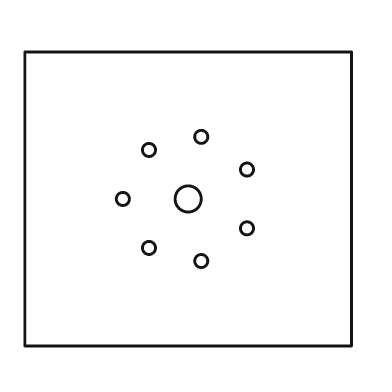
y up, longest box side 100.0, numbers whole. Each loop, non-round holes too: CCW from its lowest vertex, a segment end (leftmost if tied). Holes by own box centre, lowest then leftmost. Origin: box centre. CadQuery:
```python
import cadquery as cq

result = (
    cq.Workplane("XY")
    .moveTo(-50.0, -45.0)
    .lineTo(50.0, -45.0)
    .lineTo(50.0, 45.0)
    .lineTo(-50.0, 45.0)
    .close()
    .moveTo(4.0, -19.0)
    .circle(2.0)
    .moveTo(-12.0, -15.0)
    .circle(2.0)
    .moveTo(18.0, -9.0)
    .circle(2.0)
    .moveTo(-20.0, 0.0)
    .circle(2.0)
    .moveTo(0.0, 0.0)
    .circle(4.0)
    .moveTo(18.0, 9.0)
    .circle(2.0)
    .moveTo(-12.0, 15.0)
    .circle(2.0)
    .moveTo(4.0, 19.0)
    .circle(2.0)
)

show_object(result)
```